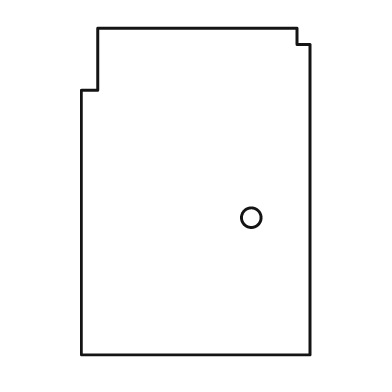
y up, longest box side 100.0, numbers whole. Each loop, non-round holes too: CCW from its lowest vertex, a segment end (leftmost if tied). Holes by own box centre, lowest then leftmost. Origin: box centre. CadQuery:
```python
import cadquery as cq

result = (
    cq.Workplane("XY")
    .moveTo(-35.0, -50.0)
    .lineTo(35.0, -50.0)
    .lineTo(35.0, 45.0)
    .lineTo(31.0, 45.0)
    .lineTo(31.0, 50.0)
    .lineTo(-30.0, 50.0)
    .lineTo(-30.0, 31.0)
    .lineTo(-35.0, 31.0)
    .close()
    .moveTo(17.0, -8.0)
    .circle(3.0)
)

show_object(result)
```